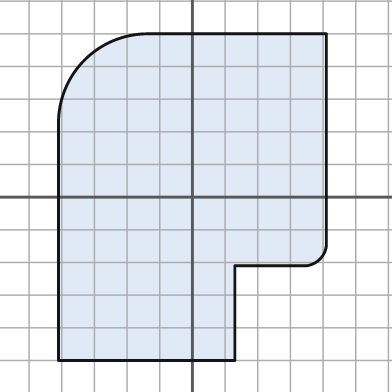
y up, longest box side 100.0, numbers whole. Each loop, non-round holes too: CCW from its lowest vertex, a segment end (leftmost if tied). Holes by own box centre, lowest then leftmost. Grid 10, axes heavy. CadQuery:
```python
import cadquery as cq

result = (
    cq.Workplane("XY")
    .moveTo(-41.0, -50.0)
    .lineTo(13.0, -50.0)
    .lineTo(13.0, -21.0)
    .lineTo(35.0, -21.0)
    .threePointArc((39.0, -19.0), (41.0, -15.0))
    .lineTo(41.0, 50.0)
    .lineTo(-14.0, 50.0)
    .threePointArc((-33.0, 42.0), (-41.0, 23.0))
    .close()
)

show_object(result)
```